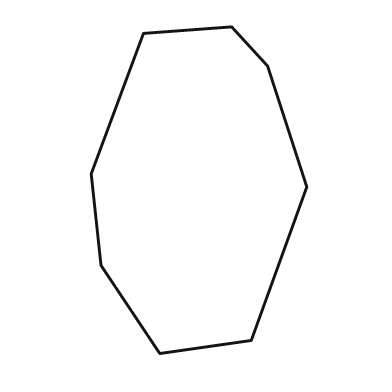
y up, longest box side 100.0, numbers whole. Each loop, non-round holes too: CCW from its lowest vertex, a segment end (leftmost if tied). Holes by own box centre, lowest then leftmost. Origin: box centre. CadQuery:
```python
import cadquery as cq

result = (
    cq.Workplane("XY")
    .moveTo(-12.0, -50.0)
    .lineTo(16.0, -46.0)
    .lineTo(33.0, 1.0)
    .lineTo(21.0, 38.0)
    .lineTo(10.0, 50.0)
    .lineTo(-17.0, 48.0)
    .lineTo(-33.0, 5.0)
    .lineTo(-30.0, -23.0)
    .close()
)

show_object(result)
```